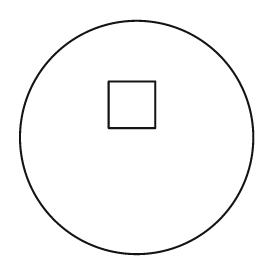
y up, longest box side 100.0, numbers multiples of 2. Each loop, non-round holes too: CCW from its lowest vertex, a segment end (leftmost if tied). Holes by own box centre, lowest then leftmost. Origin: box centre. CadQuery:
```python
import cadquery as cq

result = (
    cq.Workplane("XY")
    .moveTo(0.0, 0.0)
    .circle(50.0)
    .moveTo(-12.0, 4.0)
    .lineTo(8.0, 4.0)
    .lineTo(8.0, 24.0)
    .lineTo(-12.0, 24.0)
    .close()
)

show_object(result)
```